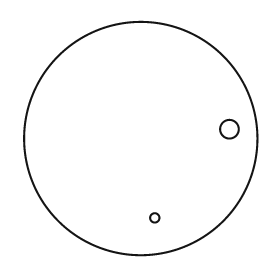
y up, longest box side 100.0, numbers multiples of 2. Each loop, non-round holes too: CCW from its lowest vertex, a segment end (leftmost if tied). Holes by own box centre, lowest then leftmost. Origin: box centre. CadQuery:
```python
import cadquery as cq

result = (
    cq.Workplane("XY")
    .moveTo(0.0, 0.0)
    .circle(50.0)
    .moveTo(6.0, -34.0)
    .circle(2.0)
    .moveTo(38.0, 4.0)
    .circle(4.0)
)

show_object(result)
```